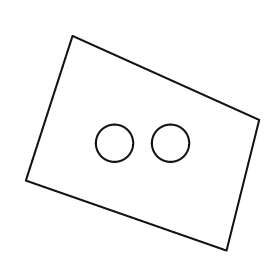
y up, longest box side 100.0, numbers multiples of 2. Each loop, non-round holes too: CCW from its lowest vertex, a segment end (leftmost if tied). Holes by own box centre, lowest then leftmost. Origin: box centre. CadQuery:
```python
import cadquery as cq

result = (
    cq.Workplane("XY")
    .moveTo(36.0, -46.0)
    .lineTo(50.0, 10.0)
    .lineTo(-30.0, 46.0)
    .lineTo(-50.0, -16.0)
    .close()
    .moveTo(-12.0, 0.0)
    .circle(8.0)
    .moveTo(12.0, 0.0)
    .circle(8.0)
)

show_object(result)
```